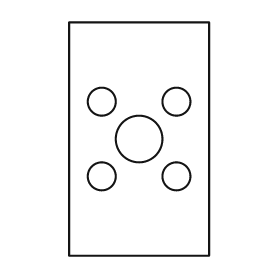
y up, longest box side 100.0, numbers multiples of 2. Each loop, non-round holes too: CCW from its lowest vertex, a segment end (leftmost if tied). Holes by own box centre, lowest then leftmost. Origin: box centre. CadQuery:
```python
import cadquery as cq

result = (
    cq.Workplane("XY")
    .moveTo(-30.0, -50.0)
    .lineTo(30.0, -50.0)
    .lineTo(30.0, 50.0)
    .lineTo(-30.0, 50.0)
    .close()
    .moveTo(-16.0, -16.0)
    .circle(6.0)
    .moveTo(16.0, -16.0)
    .circle(6.0)
    .moveTo(0.0, 0.0)
    .circle(10.0)
    .moveTo(-16.0, 16.0)
    .circle(6.0)
    .moveTo(16.0, 16.0)
    .circle(6.0)
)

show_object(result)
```